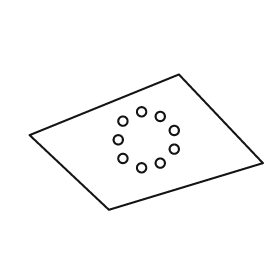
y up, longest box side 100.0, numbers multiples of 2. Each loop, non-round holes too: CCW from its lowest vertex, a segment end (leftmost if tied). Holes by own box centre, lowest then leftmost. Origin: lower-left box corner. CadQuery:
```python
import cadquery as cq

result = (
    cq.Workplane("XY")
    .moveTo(34.0, 0.0)
    .lineTo(100.0, 20.0)
    .lineTo(64.0, 58.0)
    .lineTo(0.0, 32.0)
    .close()
    .moveTo(48.0, 18.0)
    .circle(2.0)
    .moveTo(56.0, 20.0)
    .circle(2.0)
    .moveTo(40.0, 22.0)
    .circle(2.0)
    .moveTo(62.0, 26.0)
    .circle(2.0)
    .moveTo(38.0, 30.0)
    .circle(2.0)
    .moveTo(62.0, 34.0)
    .circle(2.0)
    .moveTo(40.0, 38.0)
    .circle(2.0)
    .moveTo(56.0, 40.0)
    .circle(2.0)
    .moveTo(48.0, 42.0)
    .circle(2.0)
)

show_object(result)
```